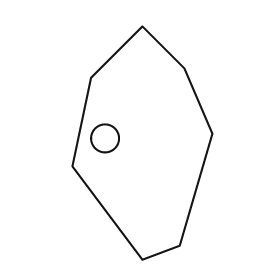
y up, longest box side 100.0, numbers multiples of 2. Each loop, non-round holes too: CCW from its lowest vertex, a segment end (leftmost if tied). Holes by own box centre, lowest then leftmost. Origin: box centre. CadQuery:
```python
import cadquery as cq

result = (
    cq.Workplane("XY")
    .moveTo(0.0, -50.0)
    .lineTo(16.0, -44.0)
    .lineTo(30.0, 4.0)
    .lineTo(18.0, 32.0)
    .lineTo(0.0, 50.0)
    .lineTo(-22.0, 28.0)
    .lineTo(-30.0, -10.0)
    .close()
    .moveTo(-16.0, 2.0)
    .circle(6.0)
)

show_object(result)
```